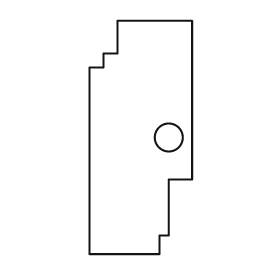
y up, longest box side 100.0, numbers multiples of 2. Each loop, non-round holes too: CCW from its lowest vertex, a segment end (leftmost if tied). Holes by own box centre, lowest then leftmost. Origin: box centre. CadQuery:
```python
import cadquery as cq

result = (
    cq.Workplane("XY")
    .moveTo(-22.0, -50.0)
    .lineTo(8.0, -50.0)
    .lineTo(8.0, -42.0)
    .lineTo(12.0, -42.0)
    .lineTo(12.0, -18.0)
    .lineTo(22.0, -18.0)
    .lineTo(22.0, 50.0)
    .lineTo(-10.0, 50.0)
    .lineTo(-10.0, 36.0)
    .lineTo(-16.0, 36.0)
    .lineTo(-16.0, 30.0)
    .lineTo(-22.0, 30.0)
    .close()
    .moveTo(12.0, 0.0)
    .circle(6.0)
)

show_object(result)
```